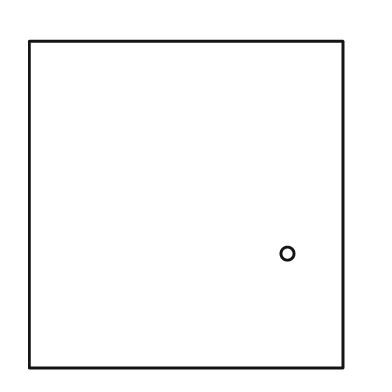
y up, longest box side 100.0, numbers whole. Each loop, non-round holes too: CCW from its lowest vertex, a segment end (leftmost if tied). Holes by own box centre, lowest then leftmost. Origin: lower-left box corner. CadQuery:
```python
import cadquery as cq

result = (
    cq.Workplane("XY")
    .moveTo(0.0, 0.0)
    .lineTo(96.0, 0.0)
    .lineTo(96.0, 100.0)
    .lineTo(0.0, 100.0)
    .close()
    .moveTo(79.0, 35.0)
    .circle(2.0)
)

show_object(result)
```